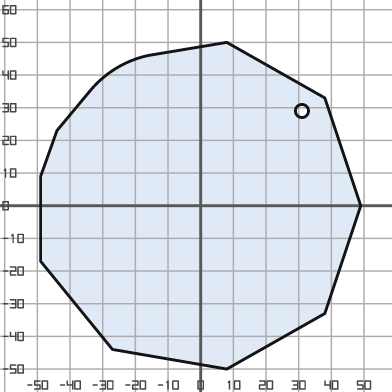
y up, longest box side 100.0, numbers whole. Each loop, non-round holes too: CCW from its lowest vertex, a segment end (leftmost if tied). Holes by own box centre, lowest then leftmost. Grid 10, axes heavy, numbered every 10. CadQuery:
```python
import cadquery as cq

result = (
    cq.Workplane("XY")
    .moveTo(8.0, -50.0)
    .lineTo(38.0, -33.0)
    .lineTo(49.0, 0.0)
    .lineTo(38.0, 33.0)
    .lineTo(8.0, 50.0)
    .lineTo(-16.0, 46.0)
    .threePointArc((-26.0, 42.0), (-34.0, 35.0))
    .lineTo(-44.0, 23.0)
    .lineTo(-49.0, 9.0)
    .lineTo(-49.0, -17.0)
    .lineTo(-27.0, -44.0)
    .close()
    .moveTo(31.0, 29.0)
    .circle(2.0)
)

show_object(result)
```